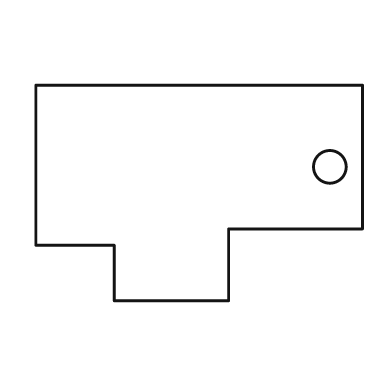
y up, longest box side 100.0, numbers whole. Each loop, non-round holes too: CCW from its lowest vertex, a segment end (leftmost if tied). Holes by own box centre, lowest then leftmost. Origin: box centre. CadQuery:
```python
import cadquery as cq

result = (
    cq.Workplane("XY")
    .moveTo(-26.0, -33.0)
    .lineTo(9.0, -33.0)
    .lineTo(9.0, -11.0)
    .lineTo(50.0, -11.0)
    .lineTo(50.0, 33.0)
    .lineTo(-50.0, 33.0)
    .lineTo(-50.0, -16.0)
    .lineTo(-26.0, -16.0)
    .close()
    .moveTo(40.0, 8.0)
    .circle(5.0)
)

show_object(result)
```